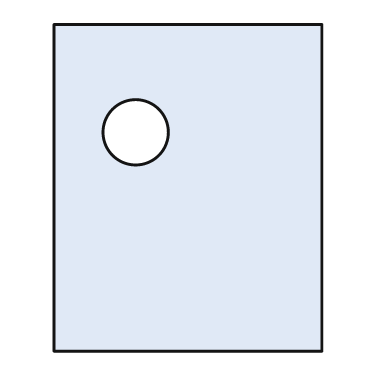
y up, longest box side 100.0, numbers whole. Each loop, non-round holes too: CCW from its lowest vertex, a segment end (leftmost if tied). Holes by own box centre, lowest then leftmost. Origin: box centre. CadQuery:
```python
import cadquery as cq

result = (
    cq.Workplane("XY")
    .moveTo(-41.0, -50.0)
    .lineTo(41.0, -50.0)
    .lineTo(41.0, 50.0)
    .lineTo(-41.0, 50.0)
    .close()
    .moveTo(-16.0, 17.0)
    .circle(10.0)
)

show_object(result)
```